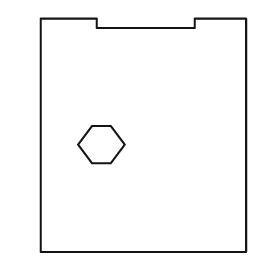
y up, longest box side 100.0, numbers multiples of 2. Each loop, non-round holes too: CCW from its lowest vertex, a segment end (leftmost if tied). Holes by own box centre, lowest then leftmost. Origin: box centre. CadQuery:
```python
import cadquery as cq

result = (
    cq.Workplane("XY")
    .moveTo(-44.0, -50.0)
    .lineTo(44.0, -50.0)
    .lineTo(44.0, 50.0)
    .lineTo(22.0, 50.0)
    .lineTo(22.0, 46.0)
    .lineTo(-20.0, 46.0)
    .lineTo(-20.0, 50.0)
    .lineTo(-44.0, 50.0)
    .close()
    .moveTo(-22.0, -12.0)
    .lineTo(-14.0, -12.0)
    .lineTo(-8.0, -4.0)
    .lineTo(-14.0, 4.0)
    .lineTo(-22.0, 4.0)
    .lineTo(-28.0, -4.0)
    .close()
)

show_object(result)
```